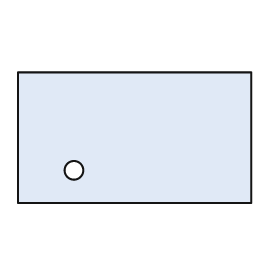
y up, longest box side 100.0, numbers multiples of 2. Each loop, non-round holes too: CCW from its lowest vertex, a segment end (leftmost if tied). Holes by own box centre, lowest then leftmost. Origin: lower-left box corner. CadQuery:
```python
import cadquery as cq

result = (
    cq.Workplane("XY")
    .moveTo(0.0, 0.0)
    .lineTo(100.0, 0.0)
    .lineTo(100.0, 56.0)
    .lineTo(0.0, 56.0)
    .close()
    .moveTo(24.0, 14.0)
    .circle(4.0)
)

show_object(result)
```